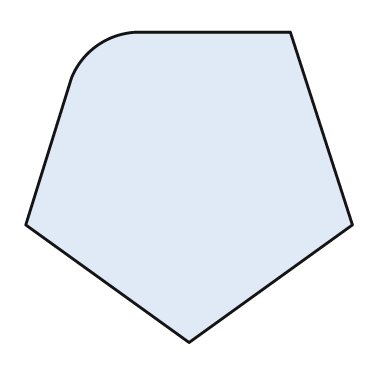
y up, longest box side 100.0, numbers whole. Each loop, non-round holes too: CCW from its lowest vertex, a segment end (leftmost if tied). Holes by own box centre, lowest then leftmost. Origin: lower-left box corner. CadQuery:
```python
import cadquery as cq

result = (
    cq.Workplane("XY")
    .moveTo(50.0, 0.0)
    .lineTo(100.0, 36.0)
    .lineTo(81.0, 95.0)
    .lineTo(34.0, 95.0)
    .threePointArc((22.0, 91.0), (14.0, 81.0))
    .lineTo(0.0, 36.0)
    .close()
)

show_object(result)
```